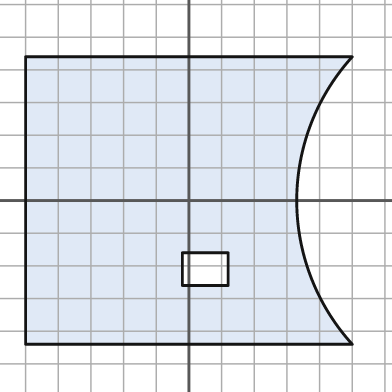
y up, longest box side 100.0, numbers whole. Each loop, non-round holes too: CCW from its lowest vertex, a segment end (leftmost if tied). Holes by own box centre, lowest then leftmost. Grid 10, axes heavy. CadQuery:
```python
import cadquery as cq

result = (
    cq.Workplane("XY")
    .moveTo(-50.0, -44.0)
    .lineTo(50.0, -44.0)
    .threePointArc((33.0, 0.0), (50.0, 44.0))
    .lineTo(-50.0, 44.0)
    .close()
    .moveTo(-2.0, -26.0)
    .lineTo(12.0, -26.0)
    .lineTo(12.0, -16.0)
    .lineTo(-2.0, -16.0)
    .close()
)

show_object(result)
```